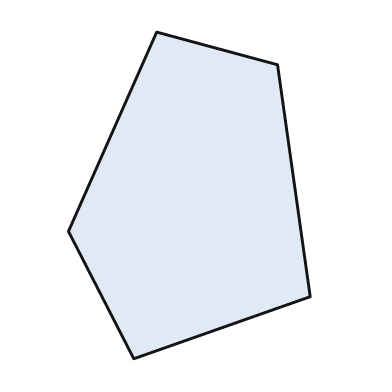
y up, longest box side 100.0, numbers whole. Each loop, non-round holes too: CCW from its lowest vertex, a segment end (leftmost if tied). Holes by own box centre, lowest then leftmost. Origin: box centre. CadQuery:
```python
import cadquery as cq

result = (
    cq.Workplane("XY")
    .moveTo(-17.0, -50.0)
    .lineTo(37.0, -31.0)
    .lineTo(27.0, 40.0)
    .lineTo(-10.0, 50.0)
    .lineTo(-37.0, -11.0)
    .close()
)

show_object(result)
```